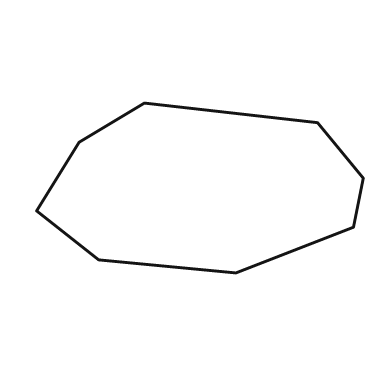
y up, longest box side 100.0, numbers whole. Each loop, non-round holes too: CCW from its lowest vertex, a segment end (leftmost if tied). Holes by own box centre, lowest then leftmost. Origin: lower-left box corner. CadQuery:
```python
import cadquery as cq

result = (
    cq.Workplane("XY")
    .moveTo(61.0, 0.0)
    .lineTo(97.0, 14.0)
    .lineTo(100.0, 29.0)
    .lineTo(86.0, 46.0)
    .lineTo(33.0, 52.0)
    .lineTo(13.0, 40.0)
    .lineTo(0.0, 19.0)
    .lineTo(19.0, 4.0)
    .close()
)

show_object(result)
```